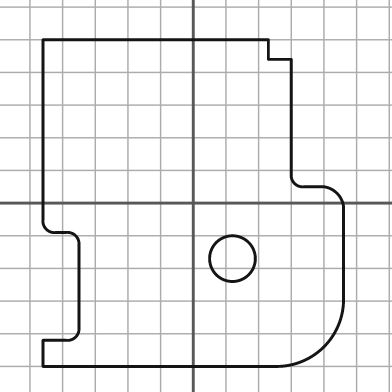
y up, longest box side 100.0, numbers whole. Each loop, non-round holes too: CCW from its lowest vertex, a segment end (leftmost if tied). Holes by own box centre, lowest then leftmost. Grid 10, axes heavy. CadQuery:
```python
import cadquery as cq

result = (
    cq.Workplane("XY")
    .moveTo(-46.0, -50.0)
    .lineTo(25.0, -50.0)
    .threePointArc((40.0, -44.0), (46.0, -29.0))
    .lineTo(46.0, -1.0)
    .threePointArc((44.0, 3.0), (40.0, 5.0))
    .lineTo(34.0, 5.0)
    .threePointArc((31.0, 6.0), (30.0, 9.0))
    .lineTo(30.0, 44.0)
    .lineTo(23.0, 44.0)
    .lineTo(23.0, 50.0)
    .lineTo(-46.0, 50.0)
    .lineTo(-46.0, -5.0)
    .threePointArc((-45.0, -8.0), (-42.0, -9.0))
    .lineTo(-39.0, -9.0)
    .threePointArc((-36.0, -10.0), (-35.0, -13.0))
    .lineTo(-35.0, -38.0)
    .threePointArc((-36.0, -41.0), (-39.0, -42.0))
    .lineTo(-46.0, -42.0)
    .close()
    .moveTo(12.0, -17.0)
    .circle(7.0)
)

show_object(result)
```